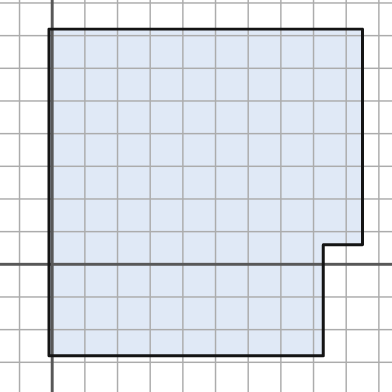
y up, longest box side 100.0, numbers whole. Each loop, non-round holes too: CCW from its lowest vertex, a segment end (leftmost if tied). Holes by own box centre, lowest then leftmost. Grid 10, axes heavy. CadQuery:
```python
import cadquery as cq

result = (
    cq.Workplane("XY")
    .moveTo(-1.0, -28.0)
    .lineTo(83.0, -28.0)
    .lineTo(83.0, 6.0)
    .lineTo(95.0, 6.0)
    .lineTo(95.0, 72.0)
    .lineTo(-1.0, 72.0)
    .close()
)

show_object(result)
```